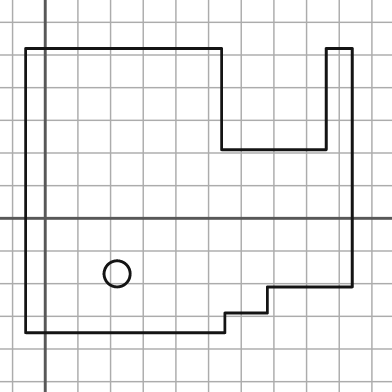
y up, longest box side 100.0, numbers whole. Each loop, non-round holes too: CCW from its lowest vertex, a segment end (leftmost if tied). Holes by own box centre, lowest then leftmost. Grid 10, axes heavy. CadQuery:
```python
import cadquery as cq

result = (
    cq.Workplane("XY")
    .moveTo(-6.0, -35.0)
    .lineTo(55.0, -35.0)
    .lineTo(55.0, -29.0)
    .lineTo(68.0, -29.0)
    .lineTo(68.0, -21.0)
    .lineTo(94.0, -21.0)
    .lineTo(94.0, 52.0)
    .lineTo(86.0, 52.0)
    .lineTo(86.0, 21.0)
    .lineTo(54.0, 21.0)
    .lineTo(54.0, 52.0)
    .lineTo(-6.0, 52.0)
    .close()
    .moveTo(22.0, -17.0)
    .circle(4.0)
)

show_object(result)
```